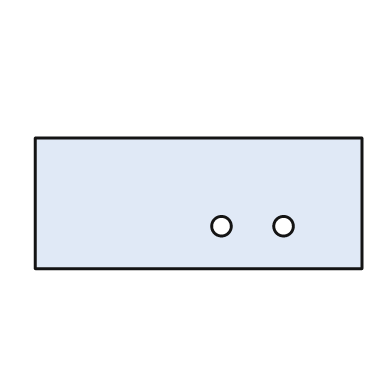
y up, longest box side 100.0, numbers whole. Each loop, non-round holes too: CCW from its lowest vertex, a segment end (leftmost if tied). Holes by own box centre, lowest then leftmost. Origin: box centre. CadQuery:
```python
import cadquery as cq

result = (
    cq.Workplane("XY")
    .moveTo(-50.0, -20.0)
    .lineTo(50.0, -20.0)
    .lineTo(50.0, 20.0)
    .lineTo(-50.0, 20.0)
    .close()
    .moveTo(7.0, -7.0)
    .circle(3.0)
    .moveTo(26.0, -7.0)
    .circle(3.0)
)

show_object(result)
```